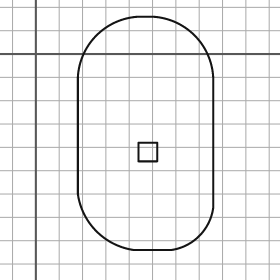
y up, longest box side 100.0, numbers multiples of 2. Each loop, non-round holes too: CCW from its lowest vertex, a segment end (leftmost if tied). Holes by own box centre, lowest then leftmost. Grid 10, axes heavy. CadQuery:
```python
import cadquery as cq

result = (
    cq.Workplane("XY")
    .moveTo(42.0, -84.0)
    .lineTo(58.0, -84.0)
    .threePointArc((70.0, -78.0), (76.0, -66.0))
    .lineTo(76.0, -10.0)
    .threePointArc((68.0, 8.0), (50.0, 16.0))
    .lineTo(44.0, 16.0)
    .threePointArc((26.0, 8.0), (18.0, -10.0))
    .lineTo(18.0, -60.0)
    .threePointArc((26.0, -76.0), (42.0, -84.0))
    .close()
    .moveTo(44.0, -46.0)
    .lineTo(52.0, -46.0)
    .lineTo(52.0, -38.0)
    .lineTo(44.0, -38.0)
    .close()
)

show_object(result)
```